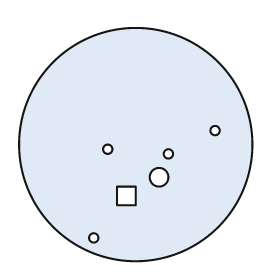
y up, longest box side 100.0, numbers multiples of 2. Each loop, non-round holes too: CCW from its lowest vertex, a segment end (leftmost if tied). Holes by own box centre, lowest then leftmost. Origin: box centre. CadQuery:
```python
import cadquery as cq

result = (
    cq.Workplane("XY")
    .moveTo(0.0, 0.0)
    .circle(50.0)
    .moveTo(-18.0, -40.0)
    .circle(2.0)
    .moveTo(-8.0, -26.0)
    .lineTo(0.0, -26.0)
    .lineTo(0.0, -18.0)
    .lineTo(-8.0, -18.0)
    .close()
    .moveTo(10.0, -14.0)
    .circle(4.0)
    .moveTo(14.0, -4.0)
    .circle(2.0)
    .moveTo(-12.0, -2.0)
    .circle(2.0)
    .moveTo(34.0, 6.0)
    .circle(2.0)
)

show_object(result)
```